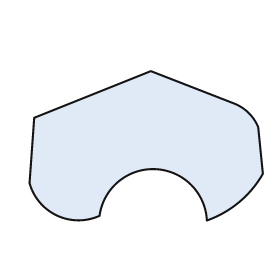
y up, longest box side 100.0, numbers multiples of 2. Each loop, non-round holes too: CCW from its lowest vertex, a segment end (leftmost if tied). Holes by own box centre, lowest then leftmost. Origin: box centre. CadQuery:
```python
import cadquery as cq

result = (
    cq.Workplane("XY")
    .moveTo(26.0, -32.0)
    .threePointArc((40.0, -24.0), (50.0, -12.0))
    .lineTo(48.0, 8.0)
    .threePointArc((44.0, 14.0), (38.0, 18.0))
    .lineTo(2.0, 32.0)
    .lineTo(-48.0, 12.0)
    .lineTo(-50.0, -16.0)
    .threePointArc((-38.0, -30.0), (-20.0, -30.0))
    .threePointArc((4.0, -10.0), (26.0, -32.0))
    .close()
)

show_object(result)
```